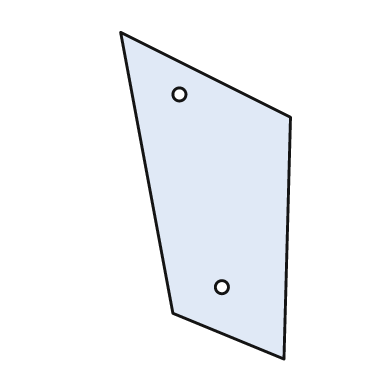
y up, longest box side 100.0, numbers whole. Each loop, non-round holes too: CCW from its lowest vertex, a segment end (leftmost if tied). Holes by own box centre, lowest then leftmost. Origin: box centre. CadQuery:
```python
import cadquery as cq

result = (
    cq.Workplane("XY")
    .moveTo(24.0, -50.0)
    .lineTo(26.0, 24.0)
    .lineTo(-26.0, 50.0)
    .lineTo(-10.0, -36.0)
    .close()
    .moveTo(5.0, -28.0)
    .circle(2.0)
    .moveTo(-8.0, 31.0)
    .circle(2.0)
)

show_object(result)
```